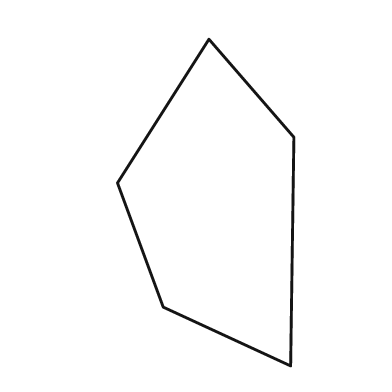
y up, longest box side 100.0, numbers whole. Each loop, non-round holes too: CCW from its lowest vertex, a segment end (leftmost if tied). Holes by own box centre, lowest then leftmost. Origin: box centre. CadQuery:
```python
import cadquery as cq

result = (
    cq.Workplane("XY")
    .moveTo(26.0, -50.0)
    .lineTo(27.0, 20.0)
    .lineTo(1.0, 50.0)
    .lineTo(-27.0, 6.0)
    .lineTo(-13.0, -32.0)
    .close()
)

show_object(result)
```